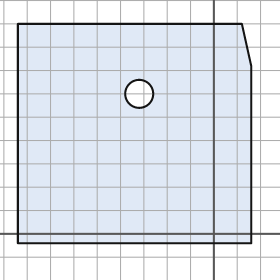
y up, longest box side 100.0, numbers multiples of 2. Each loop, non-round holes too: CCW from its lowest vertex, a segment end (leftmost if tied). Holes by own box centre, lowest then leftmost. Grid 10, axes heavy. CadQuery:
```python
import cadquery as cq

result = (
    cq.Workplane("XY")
    .moveTo(-84.0, -4.0)
    .lineTo(16.0, -4.0)
    .lineTo(16.0, 72.0)
    .lineTo(12.0, 90.0)
    .lineTo(-84.0, 90.0)
    .close()
    .moveTo(-32.0, 60.0)
    .circle(6.0)
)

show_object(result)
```